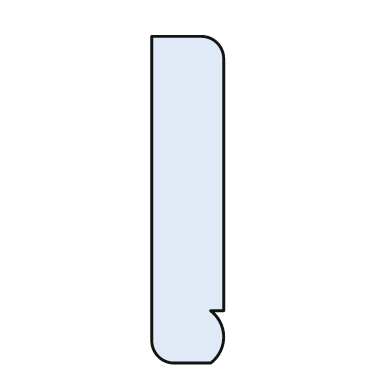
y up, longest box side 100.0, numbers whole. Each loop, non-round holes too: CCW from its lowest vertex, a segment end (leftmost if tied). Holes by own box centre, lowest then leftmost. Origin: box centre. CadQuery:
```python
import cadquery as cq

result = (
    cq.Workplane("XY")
    .moveTo(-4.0, -50.0)
    .lineTo(7.0, -50.0)
    .threePointArc((11.0, -42.0), (7.0, -34.0))
    .lineTo(11.0, -34.0)
    .lineTo(11.0, 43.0)
    .threePointArc((9.0, 48.0), (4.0, 50.0))
    .lineTo(-11.0, 50.0)
    .lineTo(-11.0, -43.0)
    .threePointArc((-9.0, -48.0), (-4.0, -50.0))
    .close()
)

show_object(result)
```